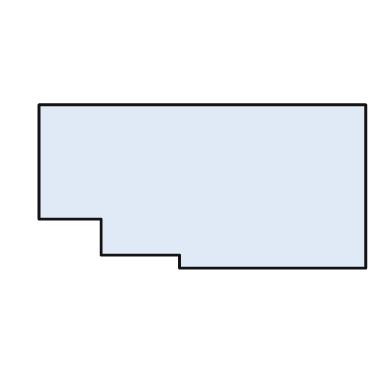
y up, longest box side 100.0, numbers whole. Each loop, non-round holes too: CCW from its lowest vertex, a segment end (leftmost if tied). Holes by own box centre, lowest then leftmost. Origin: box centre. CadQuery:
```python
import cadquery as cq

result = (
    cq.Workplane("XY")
    .moveTo(-7.0, -25.0)
    .lineTo(50.0, -25.0)
    .lineTo(50.0, 25.0)
    .lineTo(-50.0, 25.0)
    .lineTo(-50.0, -10.0)
    .lineTo(-31.0, -10.0)
    .lineTo(-31.0, -21.0)
    .lineTo(-7.0, -21.0)
    .close()
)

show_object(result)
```